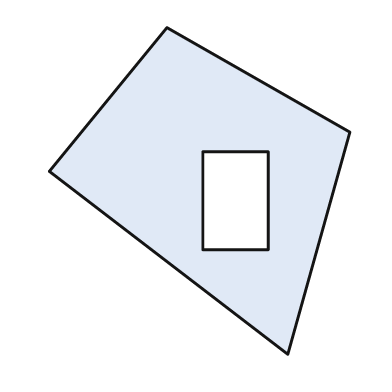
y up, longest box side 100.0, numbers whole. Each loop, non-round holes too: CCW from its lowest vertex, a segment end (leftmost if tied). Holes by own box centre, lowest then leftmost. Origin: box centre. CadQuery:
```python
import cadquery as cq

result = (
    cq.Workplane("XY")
    .moveTo(27.0, -50.0)
    .lineTo(46.0, 18.0)
    .lineTo(-10.0, 50.0)
    .lineTo(-46.0, 6.0)
    .close()
    .moveTo(1.0, -18.0)
    .lineTo(21.0, -18.0)
    .lineTo(21.0, 12.0)
    .lineTo(1.0, 12.0)
    .close()
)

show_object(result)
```